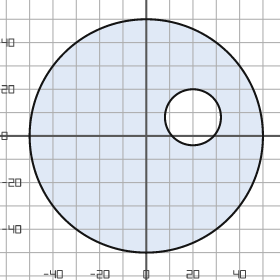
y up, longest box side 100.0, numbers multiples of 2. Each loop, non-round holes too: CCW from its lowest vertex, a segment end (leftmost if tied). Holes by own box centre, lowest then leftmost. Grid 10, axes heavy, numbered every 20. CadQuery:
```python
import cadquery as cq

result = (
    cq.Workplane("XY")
    .moveTo(0.0, 0.0)
    .circle(50.0)
    .moveTo(20.0, 8.0)
    .circle(12.0)
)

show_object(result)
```